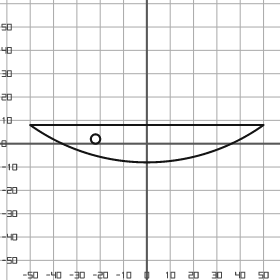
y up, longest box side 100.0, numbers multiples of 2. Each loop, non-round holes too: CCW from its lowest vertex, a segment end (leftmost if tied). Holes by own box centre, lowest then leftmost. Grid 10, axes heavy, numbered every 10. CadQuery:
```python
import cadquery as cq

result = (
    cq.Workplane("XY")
    .moveTo(-50.0, 8.0)
    .threePointArc((0.0, -8.0), (50.0, 8.0))
    .close()
    .moveTo(-22.0, 2.0)
    .circle(2.0)
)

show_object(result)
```